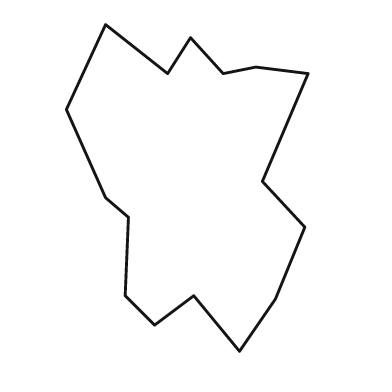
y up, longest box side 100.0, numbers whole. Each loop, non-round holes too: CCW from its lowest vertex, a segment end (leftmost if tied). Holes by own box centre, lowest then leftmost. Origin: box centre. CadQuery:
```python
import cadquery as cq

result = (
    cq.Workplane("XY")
    .moveTo(16.0, -50.0)
    .lineTo(27.0, -34.0)
    .lineTo(36.0, -12.0)
    .lineTo(23.0, 2.0)
    .lineTo(37.0, 35.0)
    .lineTo(21.0, 37.0)
    .lineTo(11.0, 35.0)
    .lineTo(1.0, 46.0)
    .lineTo(-6.0, 35.0)
    .lineTo(-25.0, 50.0)
    .lineTo(-37.0, 24.0)
    .lineTo(-25.0, -3.0)
    .lineTo(-18.0, -9.0)
    .lineTo(-19.0, -33.0)
    .lineTo(-10.0, -42.0)
    .lineTo(2.0, -33.0)
    .close()
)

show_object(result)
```